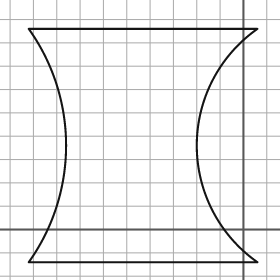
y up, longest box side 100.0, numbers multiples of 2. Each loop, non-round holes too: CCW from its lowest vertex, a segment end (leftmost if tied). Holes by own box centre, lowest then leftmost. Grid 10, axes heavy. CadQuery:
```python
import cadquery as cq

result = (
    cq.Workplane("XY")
    .moveTo(-92.0, -14.0)
    .lineTo(6.0, -14.0)
    .threePointArc((-20.0, 36.0), (6.0, 86.0))
    .lineTo(-92.0, 86.0)
    .threePointArc((-76.0, 36.0), (-92.0, -14.0))
    .close()
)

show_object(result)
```